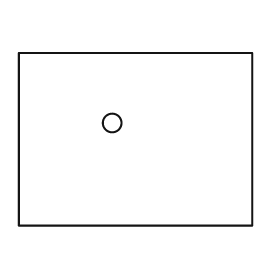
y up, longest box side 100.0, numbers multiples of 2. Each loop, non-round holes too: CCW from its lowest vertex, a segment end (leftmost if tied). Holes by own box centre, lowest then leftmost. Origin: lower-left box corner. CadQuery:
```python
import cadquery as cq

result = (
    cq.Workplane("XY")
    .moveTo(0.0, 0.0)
    .lineTo(100.0, 0.0)
    .lineTo(100.0, 74.0)
    .lineTo(0.0, 74.0)
    .close()
    .moveTo(40.0, 44.0)
    .circle(4.0)
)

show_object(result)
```